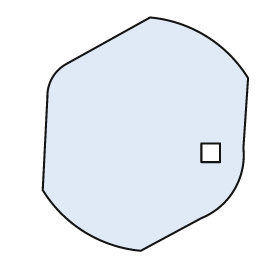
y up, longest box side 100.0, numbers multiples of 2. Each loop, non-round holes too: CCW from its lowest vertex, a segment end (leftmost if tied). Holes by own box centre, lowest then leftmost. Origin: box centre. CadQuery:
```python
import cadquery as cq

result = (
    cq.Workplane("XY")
    .moveTo(-2.0, -50.0)
    .lineTo(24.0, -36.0)
    .threePointArc((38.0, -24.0), (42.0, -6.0))
    .lineTo(44.0, 24.0)
    .threePointArc((26.0, 42.0), (2.0, 50.0))
    .lineTo(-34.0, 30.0)
    .threePointArc((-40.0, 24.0), (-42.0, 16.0))
    .lineTo(-44.0, -24.0)
    .threePointArc((-26.0, -42.0), (-2.0, -50.0))
    .close()
    .moveTo(24.0, -12.0)
    .lineTo(32.0, -12.0)
    .lineTo(32.0, -4.0)
    .lineTo(24.0, -4.0)
    .close()
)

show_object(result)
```